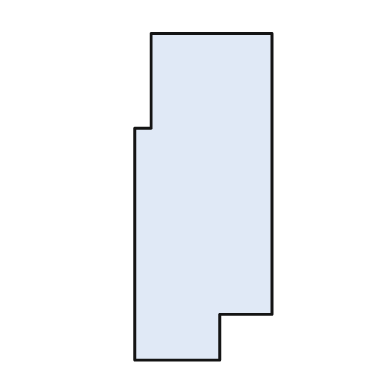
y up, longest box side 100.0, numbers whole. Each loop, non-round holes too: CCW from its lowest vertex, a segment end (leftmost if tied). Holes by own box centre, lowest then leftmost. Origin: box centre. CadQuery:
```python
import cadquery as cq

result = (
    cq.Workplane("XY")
    .moveTo(-21.0, -50.0)
    .lineTo(5.0, -50.0)
    .lineTo(5.0, -36.0)
    .lineTo(21.0, -36.0)
    .lineTo(21.0, 50.0)
    .lineTo(-16.0, 50.0)
    .lineTo(-16.0, 21.0)
    .lineTo(-21.0, 21.0)
    .close()
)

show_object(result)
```